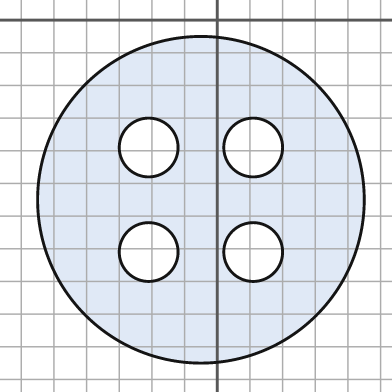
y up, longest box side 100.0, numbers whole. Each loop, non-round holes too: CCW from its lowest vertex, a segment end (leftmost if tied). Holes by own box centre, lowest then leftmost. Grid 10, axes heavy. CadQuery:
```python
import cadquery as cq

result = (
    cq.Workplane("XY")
    .moveTo(-5.0, -55.0)
    .circle(50.0)
    .moveTo(-21.0, -71.0)
    .circle(9.0)
    .moveTo(11.0, -71.0)
    .circle(9.0)
    .moveTo(-21.0, -39.0)
    .circle(9.0)
    .moveTo(11.0, -39.0)
    .circle(9.0)
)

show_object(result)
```